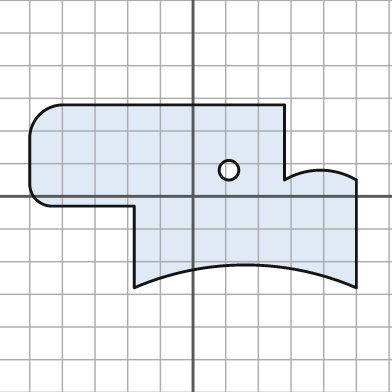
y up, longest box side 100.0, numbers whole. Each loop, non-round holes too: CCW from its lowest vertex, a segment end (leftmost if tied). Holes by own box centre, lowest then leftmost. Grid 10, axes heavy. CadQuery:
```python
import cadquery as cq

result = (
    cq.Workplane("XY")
    .moveTo(-18.0, -28.0)
    .threePointArc((16.0, -21.0), (50.0, -28.0))
    .lineTo(50.0, 5.0)
    .threePointArc((39.0, 8.0), (28.0, 5.0))
    .lineTo(28.0, 28.0)
    .lineTo(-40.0, 28.0)
    .threePointArc((-47.0, 25.0), (-50.0, 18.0))
    .lineTo(-50.0, 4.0)
    .threePointArc((-48.0, -1.0), (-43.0, -3.0))
    .lineTo(-18.0, -3.0)
    .close()
    .moveTo(11.0, 8.0)
    .circle(3.0)
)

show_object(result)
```